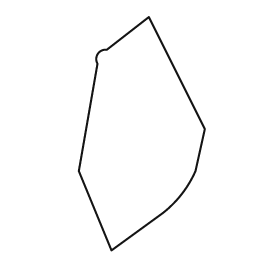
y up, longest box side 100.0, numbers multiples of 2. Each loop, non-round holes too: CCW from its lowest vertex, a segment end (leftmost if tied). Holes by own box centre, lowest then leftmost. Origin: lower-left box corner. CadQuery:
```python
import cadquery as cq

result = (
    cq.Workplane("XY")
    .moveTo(14.0, 0.0)
    .lineTo(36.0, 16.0)
    .threePointArc((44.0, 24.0), (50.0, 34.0))
    .lineTo(54.0, 52.0)
    .lineTo(30.0, 100.0)
    .lineTo(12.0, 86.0)
    .threePointArc((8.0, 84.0), (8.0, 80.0))
    .lineTo(0.0, 34.0)
    .close()
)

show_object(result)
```